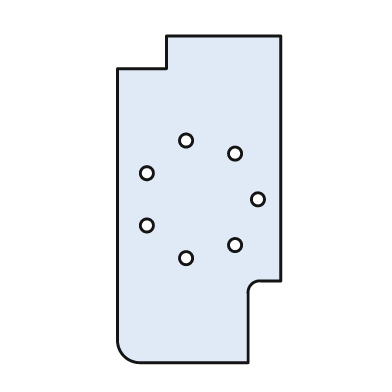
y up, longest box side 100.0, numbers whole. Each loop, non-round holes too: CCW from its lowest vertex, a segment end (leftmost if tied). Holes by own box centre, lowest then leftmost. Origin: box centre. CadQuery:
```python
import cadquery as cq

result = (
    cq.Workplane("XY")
    .moveTo(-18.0, -50.0)
    .lineTo(15.0, -50.0)
    .lineTo(15.0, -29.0)
    .threePointArc((16.0, -26.0), (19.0, -25.0))
    .lineTo(25.0, -25.0)
    .lineTo(25.0, 50.0)
    .lineTo(-10.0, 50.0)
    .lineTo(-10.0, 40.0)
    .lineTo(-25.0, 40.0)
    .lineTo(-25.0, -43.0)
    .threePointArc((-23.0, -48.0), (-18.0, -50.0))
    .close()
    .moveTo(-4.0, -18.0)
    .circle(2.0)
    .moveTo(11.0, -14.0)
    .circle(2.0)
    .moveTo(-16.0, -8.0)
    .circle(2.0)
    .moveTo(18.0, 0.0)
    .circle(2.0)
    .moveTo(-16.0, 8.0)
    .circle(2.0)
    .moveTo(11.0, 14.0)
    .circle(2.0)
    .moveTo(-4.0, 18.0)
    .circle(2.0)
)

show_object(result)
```